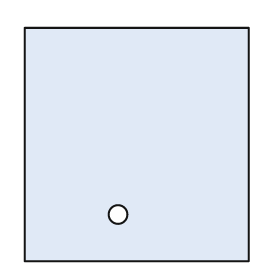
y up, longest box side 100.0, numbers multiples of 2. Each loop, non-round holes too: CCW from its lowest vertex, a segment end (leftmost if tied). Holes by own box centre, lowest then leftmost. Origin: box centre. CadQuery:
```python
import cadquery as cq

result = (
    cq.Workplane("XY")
    .moveTo(-48.0, -50.0)
    .lineTo(48.0, -50.0)
    .lineTo(48.0, 50.0)
    .lineTo(-48.0, 50.0)
    .close()
    .moveTo(-8.0, -30.0)
    .circle(4.0)
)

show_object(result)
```